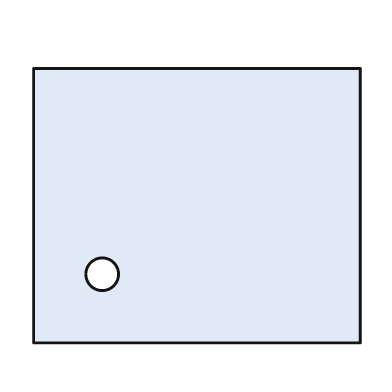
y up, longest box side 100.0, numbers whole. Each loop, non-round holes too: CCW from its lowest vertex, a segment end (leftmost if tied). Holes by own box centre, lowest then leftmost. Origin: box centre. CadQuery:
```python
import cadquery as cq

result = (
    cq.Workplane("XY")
    .moveTo(-50.0, -42.0)
    .lineTo(50.0, -42.0)
    .lineTo(50.0, 42.0)
    .lineTo(-50.0, 42.0)
    .close()
    .moveTo(-29.0, -21.0)
    .circle(5.0)
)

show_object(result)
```